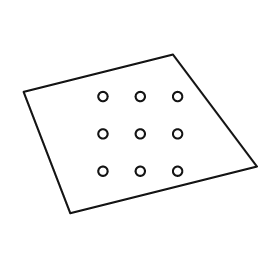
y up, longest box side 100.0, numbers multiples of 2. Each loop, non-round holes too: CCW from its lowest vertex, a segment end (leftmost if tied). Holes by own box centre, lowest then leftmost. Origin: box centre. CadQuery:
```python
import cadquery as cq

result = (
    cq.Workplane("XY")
    .moveTo(-30.0, -34.0)
    .lineTo(50.0, -14.0)
    .lineTo(14.0, 34.0)
    .lineTo(-50.0, 18.0)
    .close()
    .moveTo(-16.0, -16.0)
    .circle(2.0)
    .moveTo(0.0, -16.0)
    .circle(2.0)
    .moveTo(16.0, -16.0)
    .circle(2.0)
    .moveTo(-16.0, 0.0)
    .circle(2.0)
    .moveTo(0.0, 0.0)
    .circle(2.0)
    .moveTo(16.0, 0.0)
    .circle(2.0)
    .moveTo(-16.0, 16.0)
    .circle(2.0)
    .moveTo(0.0, 16.0)
    .circle(2.0)
    .moveTo(16.0, 16.0)
    .circle(2.0)
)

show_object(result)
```